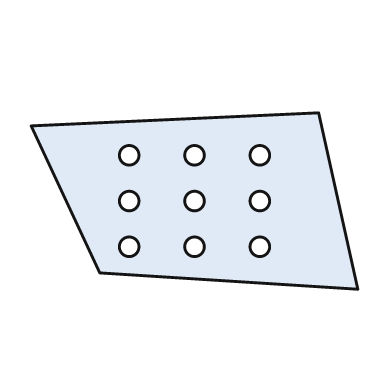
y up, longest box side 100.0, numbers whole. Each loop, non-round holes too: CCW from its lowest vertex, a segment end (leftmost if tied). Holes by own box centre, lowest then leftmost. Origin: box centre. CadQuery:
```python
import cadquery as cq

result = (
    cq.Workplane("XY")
    .moveTo(50.0, -27.0)
    .lineTo(38.0, 27.0)
    .lineTo(-50.0, 23.0)
    .lineTo(-29.0, -22.0)
    .close()
    .moveTo(-20.0, -14.0)
    .circle(3.0)
    .moveTo(0.0, -14.0)
    .circle(3.0)
    .moveTo(20.0, -14.0)
    .circle(3.0)
    .moveTo(-20.0, 0.0)
    .circle(3.0)
    .moveTo(0.0, 0.0)
    .circle(3.0)
    .moveTo(20.0, 0.0)
    .circle(3.0)
    .moveTo(-20.0, 14.0)
    .circle(3.0)
    .moveTo(0.0, 14.0)
    .circle(3.0)
    .moveTo(20.0, 14.0)
    .circle(3.0)
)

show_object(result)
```